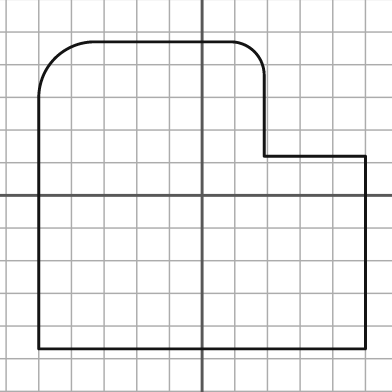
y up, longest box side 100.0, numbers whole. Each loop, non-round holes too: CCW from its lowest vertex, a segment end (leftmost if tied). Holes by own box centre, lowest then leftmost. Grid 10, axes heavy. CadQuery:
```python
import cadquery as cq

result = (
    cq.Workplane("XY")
    .moveTo(-50.0, -47.0)
    .lineTo(50.0, -47.0)
    .lineTo(50.0, 12.0)
    .lineTo(19.0, 12.0)
    .lineTo(19.0, 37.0)
    .threePointArc((16.0, 44.0), (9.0, 47.0))
    .lineTo(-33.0, 47.0)
    .threePointArc((-45.0, 42.0), (-50.0, 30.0))
    .close()
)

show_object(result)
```